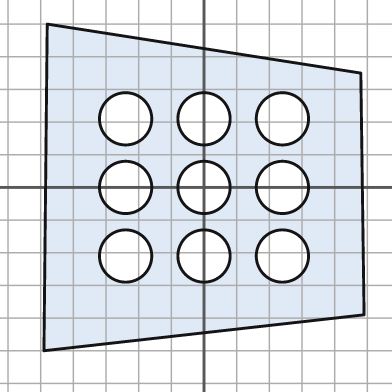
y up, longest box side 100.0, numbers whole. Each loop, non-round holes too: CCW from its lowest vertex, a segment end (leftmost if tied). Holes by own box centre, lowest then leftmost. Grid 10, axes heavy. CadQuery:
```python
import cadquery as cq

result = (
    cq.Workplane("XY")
    .moveTo(-49.0, -50.0)
    .lineTo(49.0, -39.0)
    .lineTo(48.0, 35.0)
    .lineTo(-48.0, 50.0)
    .close()
    .moveTo(-24.0, -21.0)
    .circle(8.0)
    .moveTo(0.0, -21.0)
    .circle(8.0)
    .moveTo(24.0, -21.0)
    .circle(8.0)
    .moveTo(-24.0, 0.0)
    .circle(8.0)
    .moveTo(0.0, 0.0)
    .circle(8.0)
    .moveTo(24.0, 0.0)
    .circle(8.0)
    .moveTo(-24.0, 21.0)
    .circle(8.0)
    .moveTo(0.0, 21.0)
    .circle(8.0)
    .moveTo(24.0, 21.0)
    .circle(8.0)
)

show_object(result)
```